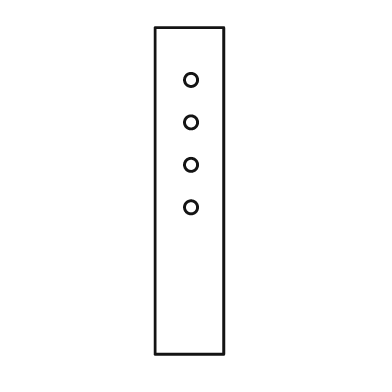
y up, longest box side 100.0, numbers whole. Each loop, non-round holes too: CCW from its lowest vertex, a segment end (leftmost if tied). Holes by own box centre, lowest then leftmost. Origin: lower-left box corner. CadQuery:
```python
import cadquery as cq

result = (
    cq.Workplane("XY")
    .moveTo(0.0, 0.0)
    .lineTo(21.0, 0.0)
    .lineTo(21.0, 100.0)
    .lineTo(0.0, 100.0)
    .close()
    .moveTo(11.0, 45.0)
    .circle(2.0)
    .moveTo(11.0, 58.0)
    .circle(2.0)
    .moveTo(11.0, 71.0)
    .circle(2.0)
    .moveTo(11.0, 84.0)
    .circle(2.0)
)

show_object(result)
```